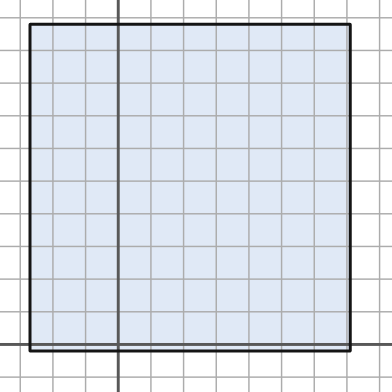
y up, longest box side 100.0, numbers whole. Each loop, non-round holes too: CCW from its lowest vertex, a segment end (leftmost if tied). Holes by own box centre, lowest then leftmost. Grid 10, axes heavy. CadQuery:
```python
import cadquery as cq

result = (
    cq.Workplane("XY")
    .moveTo(-27.0, -2.0)
    .lineTo(71.0, -2.0)
    .lineTo(71.0, 98.0)
    .lineTo(-27.0, 98.0)
    .close()
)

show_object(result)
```